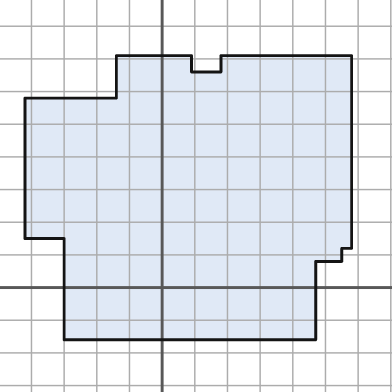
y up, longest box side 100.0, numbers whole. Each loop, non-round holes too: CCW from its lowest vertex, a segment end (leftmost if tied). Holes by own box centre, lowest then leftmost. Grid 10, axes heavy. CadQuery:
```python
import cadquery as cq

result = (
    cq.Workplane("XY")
    .moveTo(-30.0, -16.0)
    .lineTo(47.0, -16.0)
    .lineTo(47.0, 8.0)
    .lineTo(55.0, 8.0)
    .lineTo(55.0, 12.0)
    .lineTo(58.0, 12.0)
    .lineTo(58.0, 71.0)
    .lineTo(18.0, 71.0)
    .lineTo(18.0, 66.0)
    .lineTo(9.0, 66.0)
    .lineTo(9.0, 71.0)
    .lineTo(-14.0, 71.0)
    .lineTo(-14.0, 58.0)
    .lineTo(-42.0, 58.0)
    .lineTo(-42.0, 15.0)
    .lineTo(-30.0, 15.0)
    .close()
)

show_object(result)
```